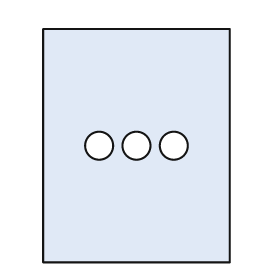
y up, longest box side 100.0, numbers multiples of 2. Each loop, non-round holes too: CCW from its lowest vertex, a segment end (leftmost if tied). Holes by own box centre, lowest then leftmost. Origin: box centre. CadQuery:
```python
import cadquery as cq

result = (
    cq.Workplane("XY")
    .moveTo(-40.0, -50.0)
    .lineTo(40.0, -50.0)
    .lineTo(40.0, 50.0)
    .lineTo(-40.0, 50.0)
    .close()
    .moveTo(-16.0, 0.0)
    .circle(6.0)
    .moveTo(0.0, 0.0)
    .circle(6.0)
    .moveTo(16.0, 0.0)
    .circle(6.0)
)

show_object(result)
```